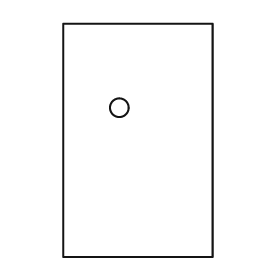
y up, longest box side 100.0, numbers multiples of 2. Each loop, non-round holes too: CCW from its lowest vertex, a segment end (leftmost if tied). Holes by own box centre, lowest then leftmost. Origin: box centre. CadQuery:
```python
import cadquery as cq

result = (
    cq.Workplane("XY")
    .moveTo(-32.0, -50.0)
    .lineTo(32.0, -50.0)
    .lineTo(32.0, 50.0)
    .lineTo(-32.0, 50.0)
    .close()
    .moveTo(-8.0, 14.0)
    .circle(4.0)
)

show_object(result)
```